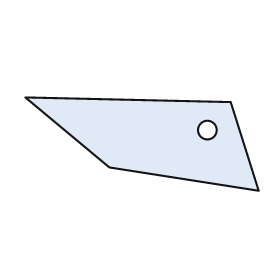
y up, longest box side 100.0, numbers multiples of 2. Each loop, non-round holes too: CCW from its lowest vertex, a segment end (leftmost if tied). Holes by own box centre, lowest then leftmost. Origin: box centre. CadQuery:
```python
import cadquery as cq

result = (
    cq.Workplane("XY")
    .moveTo(50.0, -20.0)
    .lineTo(38.0, 18.0)
    .lineTo(-50.0, 20.0)
    .lineTo(-14.0, -10.0)
    .close()
    .moveTo(28.0, 6.0)
    .circle(4.0)
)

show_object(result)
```